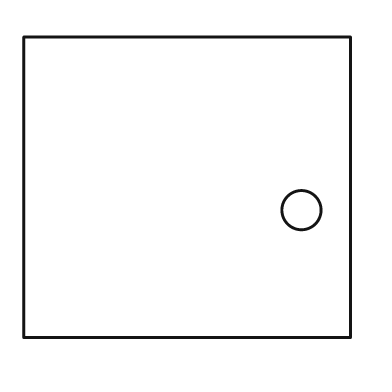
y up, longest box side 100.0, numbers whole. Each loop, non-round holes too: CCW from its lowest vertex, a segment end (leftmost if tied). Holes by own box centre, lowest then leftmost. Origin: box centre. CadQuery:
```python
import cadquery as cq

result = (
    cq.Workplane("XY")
    .moveTo(-50.0, -46.0)
    .lineTo(50.0, -46.0)
    .lineTo(50.0, 46.0)
    .lineTo(-50.0, 46.0)
    .close()
    .moveTo(35.0, -7.0)
    .circle(6.0)
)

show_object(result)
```